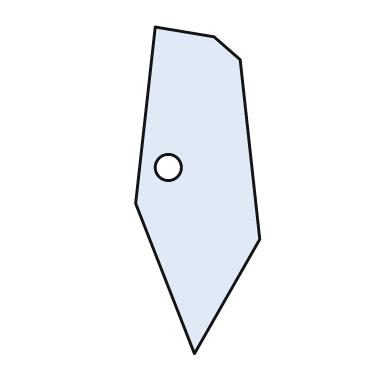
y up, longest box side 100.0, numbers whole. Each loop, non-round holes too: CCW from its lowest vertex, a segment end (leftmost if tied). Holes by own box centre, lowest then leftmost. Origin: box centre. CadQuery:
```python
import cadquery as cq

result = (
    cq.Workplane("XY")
    .moveTo(-1.0, -50.0)
    .lineTo(19.0, -15.0)
    .lineTo(13.0, 40.0)
    .lineTo(5.0, 47.0)
    .lineTo(-13.0, 50.0)
    .lineTo(-19.0, -4.0)
    .close()
    .moveTo(-9.0, 7.0)
    .circle(4.0)
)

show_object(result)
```